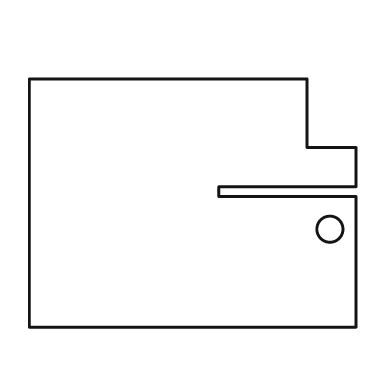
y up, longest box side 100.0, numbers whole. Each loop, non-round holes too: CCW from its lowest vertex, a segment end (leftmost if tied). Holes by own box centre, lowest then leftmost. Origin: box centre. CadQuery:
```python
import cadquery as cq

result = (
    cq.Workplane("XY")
    .moveTo(-50.0, -38.0)
    .lineTo(50.0, -38.0)
    .lineTo(50.0, 2.0)
    .lineTo(8.0, 2.0)
    .lineTo(8.0, 5.0)
    .lineTo(50.0, 5.0)
    .lineTo(50.0, 17.0)
    .lineTo(35.0, 17.0)
    .lineTo(35.0, 38.0)
    .lineTo(-50.0, 38.0)
    .close()
    .moveTo(42.0, -8.0)
    .circle(4.0)
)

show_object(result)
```